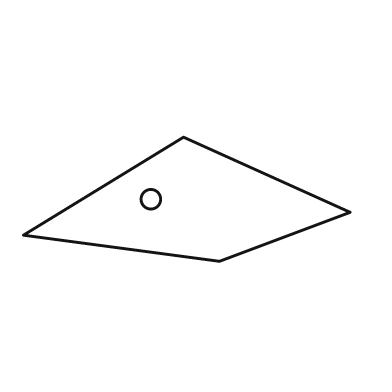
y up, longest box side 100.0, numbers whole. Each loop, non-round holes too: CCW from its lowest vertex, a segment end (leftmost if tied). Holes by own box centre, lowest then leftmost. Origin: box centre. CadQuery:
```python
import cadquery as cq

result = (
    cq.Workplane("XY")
    .moveTo(10.0, -19.0)
    .lineTo(50.0, -4.0)
    .lineTo(-1.0, 19.0)
    .lineTo(-50.0, -11.0)
    .close()
    .moveTo(-11.0, 0.0)
    .circle(3.0)
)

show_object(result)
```